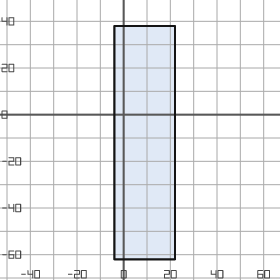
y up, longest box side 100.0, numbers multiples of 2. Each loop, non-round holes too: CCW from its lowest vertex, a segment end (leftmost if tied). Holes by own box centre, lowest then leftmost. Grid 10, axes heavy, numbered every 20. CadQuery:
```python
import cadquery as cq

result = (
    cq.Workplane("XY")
    .moveTo(-4.0, -62.0)
    .lineTo(22.0, -62.0)
    .lineTo(22.0, 38.0)
    .lineTo(-4.0, 38.0)
    .close()
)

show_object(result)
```